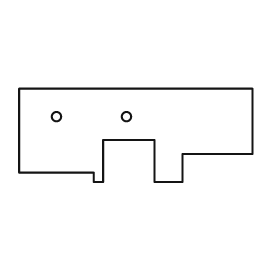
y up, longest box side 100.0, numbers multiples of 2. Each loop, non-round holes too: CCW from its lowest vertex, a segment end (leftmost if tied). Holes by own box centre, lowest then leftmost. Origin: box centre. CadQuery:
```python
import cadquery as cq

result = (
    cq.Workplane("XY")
    .moveTo(-18.0, -20.0)
    .lineTo(-14.0, -20.0)
    .lineTo(-14.0, -2.0)
    .lineTo(8.0, -2.0)
    .lineTo(8.0, -20.0)
    .lineTo(20.0, -20.0)
    .lineTo(20.0, -8.0)
    .lineTo(50.0, -8.0)
    .lineTo(50.0, 20.0)
    .lineTo(-50.0, 20.0)
    .lineTo(-50.0, -16.0)
    .lineTo(-18.0, -16.0)
    .close()
    .moveTo(-34.0, 8.0)
    .circle(2.0)
    .moveTo(-4.0, 8.0)
    .circle(2.0)
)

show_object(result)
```